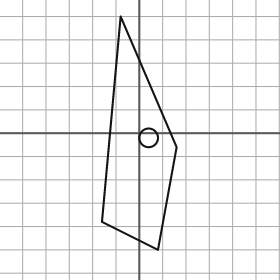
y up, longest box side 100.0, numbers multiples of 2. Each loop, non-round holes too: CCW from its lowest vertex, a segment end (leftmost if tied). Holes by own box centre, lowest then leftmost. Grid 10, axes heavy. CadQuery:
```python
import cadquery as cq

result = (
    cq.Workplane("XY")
    .moveTo(8.0, -50.0)
    .lineTo(16.0, -6.0)
    .lineTo(-8.0, 50.0)
    .lineTo(-16.0, -38.0)
    .close()
    .moveTo(4.0, -2.0)
    .circle(4.0)
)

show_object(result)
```